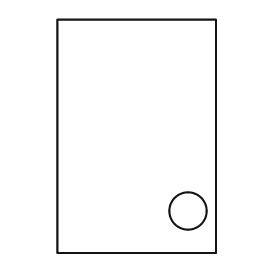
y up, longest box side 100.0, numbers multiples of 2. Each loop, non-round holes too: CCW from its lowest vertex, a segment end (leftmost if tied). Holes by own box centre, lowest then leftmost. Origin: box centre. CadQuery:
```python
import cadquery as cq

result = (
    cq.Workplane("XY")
    .moveTo(-34.0, -50.0)
    .lineTo(34.0, -50.0)
    .lineTo(34.0, 50.0)
    .lineTo(-34.0, 50.0)
    .close()
    .moveTo(22.0, -32.0)
    .circle(8.0)
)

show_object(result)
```